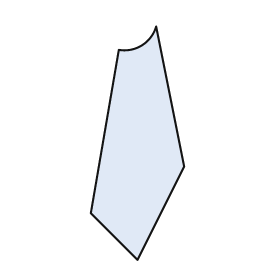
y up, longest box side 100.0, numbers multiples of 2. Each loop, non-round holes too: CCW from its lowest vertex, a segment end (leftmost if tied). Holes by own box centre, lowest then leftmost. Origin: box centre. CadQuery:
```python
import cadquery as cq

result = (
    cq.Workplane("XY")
    .moveTo(0.0, -50.0)
    .lineTo(20.0, -10.0)
    .lineTo(8.0, 50.0)
    .threePointArc((2.0, 42.0), (-8.0, 40.0))
    .lineTo(-20.0, -30.0)
    .close()
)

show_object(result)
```